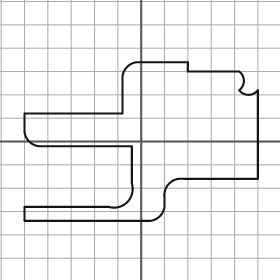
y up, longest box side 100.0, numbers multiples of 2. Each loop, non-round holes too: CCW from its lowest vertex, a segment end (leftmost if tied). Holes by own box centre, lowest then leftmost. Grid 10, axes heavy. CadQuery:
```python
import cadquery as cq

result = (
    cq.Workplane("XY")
    .moveTo(-50.0, -34.0)
    .lineTo(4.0, -34.0)
    .threePointArc((8.0, -32.0), (10.0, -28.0))
    .lineTo(10.0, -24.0)
    .threePointArc((12.0, -18.0), (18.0, -16.0))
    .lineTo(50.0, -16.0)
    .lineTo(50.0, 22.0)
    .threePointArc((46.0, 20.0), (42.0, 22.0))
    .threePointArc((44.0, 26.0), (42.0, 30.0))
    .lineTo(20.0, 30.0)
    .lineTo(20.0, 34.0)
    .lineTo(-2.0, 34.0)
    .threePointArc((-6.0, 32.0), (-8.0, 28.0))
    .lineTo(-8.0, 12.0)
    .lineTo(-50.0, 12.0)
    .lineTo(-50.0, 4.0)
    .threePointArc((-48.0, 0.0), (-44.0, -2.0))
    .lineTo(-4.0, -2.0)
    .lineTo(-4.0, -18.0)
    .threePointArc((-6.0, -26.0), (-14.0, -28.0))
    .lineTo(-50.0, -28.0)
    .close()
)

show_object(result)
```